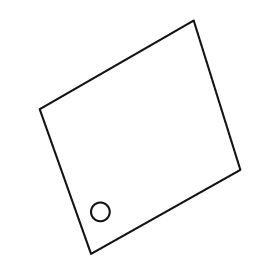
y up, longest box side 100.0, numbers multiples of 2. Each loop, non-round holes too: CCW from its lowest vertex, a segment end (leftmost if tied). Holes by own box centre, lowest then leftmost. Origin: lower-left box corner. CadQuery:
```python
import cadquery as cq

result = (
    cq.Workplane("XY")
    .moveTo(22.0, 0.0)
    .lineTo(86.0, 36.0)
    .lineTo(66.0, 100.0)
    .lineTo(0.0, 62.0)
    .close()
    .moveTo(26.0, 18.0)
    .circle(4.0)
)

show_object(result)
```